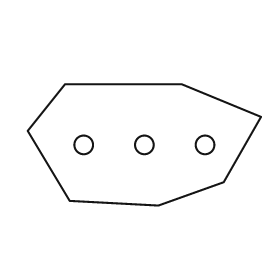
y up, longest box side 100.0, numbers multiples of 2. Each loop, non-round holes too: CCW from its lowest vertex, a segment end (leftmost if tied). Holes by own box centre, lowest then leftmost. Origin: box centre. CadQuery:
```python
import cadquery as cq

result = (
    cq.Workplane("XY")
    .moveTo(6.0, -26.0)
    .lineTo(34.0, -16.0)
    .lineTo(50.0, 12.0)
    .lineTo(16.0, 26.0)
    .lineTo(-34.0, 26.0)
    .lineTo(-50.0, 6.0)
    .lineTo(-32.0, -24.0)
    .close()
    .moveTo(-26.0, 0.0)
    .circle(4.0)
    .moveTo(0.0, 0.0)
    .circle(4.0)
    .moveTo(26.0, 0.0)
    .circle(4.0)
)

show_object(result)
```